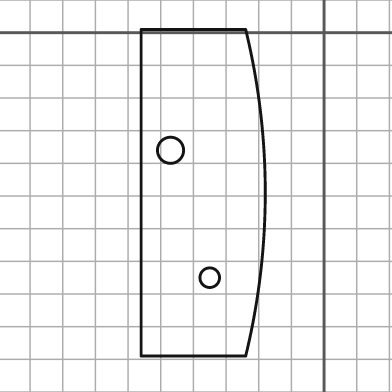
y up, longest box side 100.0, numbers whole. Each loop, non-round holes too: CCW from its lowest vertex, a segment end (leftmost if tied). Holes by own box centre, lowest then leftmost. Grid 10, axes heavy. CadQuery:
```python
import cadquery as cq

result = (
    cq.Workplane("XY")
    .moveTo(-56.0, -99.0)
    .lineTo(-24.0, -99.0)
    .threePointArc((-18.0, -49.0), (-24.0, 1.0))
    .lineTo(-56.0, 1.0)
    .close()
    .moveTo(-35.0, -75.0)
    .circle(3.0)
    .moveTo(-47.0, -36.0)
    .circle(4.0)
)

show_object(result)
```